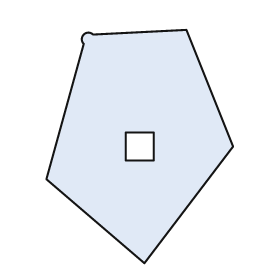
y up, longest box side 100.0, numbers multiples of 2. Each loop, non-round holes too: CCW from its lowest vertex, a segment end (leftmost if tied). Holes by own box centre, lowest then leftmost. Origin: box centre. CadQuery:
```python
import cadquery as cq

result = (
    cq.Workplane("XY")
    .moveTo(2.0, -50.0)
    .lineTo(40.0, 0.0)
    .lineTo(20.0, 50.0)
    .lineTo(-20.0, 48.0)
    .threePointArc((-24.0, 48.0), (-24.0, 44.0))
    .lineTo(-40.0, -14.0)
    .close()
    .moveTo(-6.0, -6.0)
    .lineTo(6.0, -6.0)
    .lineTo(6.0, 6.0)
    .lineTo(-6.0, 6.0)
    .close()
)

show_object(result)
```